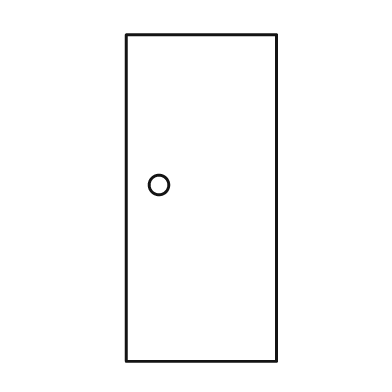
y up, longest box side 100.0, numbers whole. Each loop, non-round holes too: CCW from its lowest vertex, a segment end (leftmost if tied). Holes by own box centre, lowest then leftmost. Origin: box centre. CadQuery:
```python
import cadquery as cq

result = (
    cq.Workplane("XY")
    .moveTo(-23.0, -50.0)
    .lineTo(23.0, -50.0)
    .lineTo(23.0, 50.0)
    .lineTo(-23.0, 50.0)
    .close()
    .moveTo(-13.0, 4.0)
    .circle(3.0)
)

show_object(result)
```